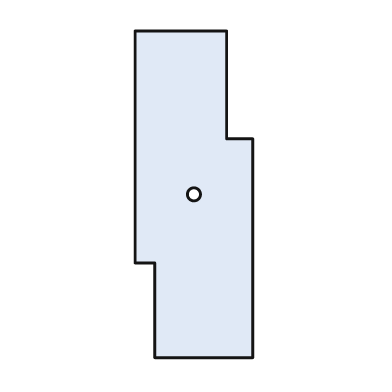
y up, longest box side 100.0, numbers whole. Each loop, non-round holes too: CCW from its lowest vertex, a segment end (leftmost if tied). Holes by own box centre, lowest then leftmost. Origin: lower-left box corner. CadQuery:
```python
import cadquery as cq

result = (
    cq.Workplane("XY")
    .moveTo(6.0, 0.0)
    .lineTo(36.0, 0.0)
    .lineTo(36.0, 67.0)
    .lineTo(28.0, 67.0)
    .lineTo(28.0, 100.0)
    .lineTo(0.0, 100.0)
    .lineTo(0.0, 29.0)
    .lineTo(6.0, 29.0)
    .close()
    .moveTo(18.0, 50.0)
    .circle(2.0)
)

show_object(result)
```